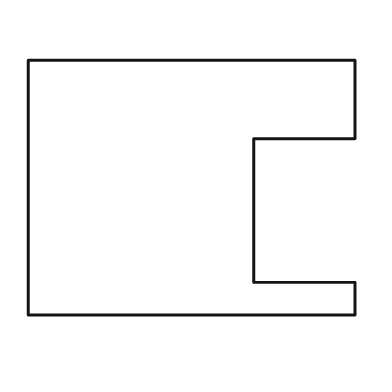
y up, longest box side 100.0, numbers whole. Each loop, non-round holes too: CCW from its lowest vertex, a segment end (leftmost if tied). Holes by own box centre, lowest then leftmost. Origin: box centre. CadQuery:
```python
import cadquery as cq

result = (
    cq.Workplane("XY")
    .moveTo(-50.0, -39.0)
    .lineTo(50.0, -39.0)
    .lineTo(50.0, -29.0)
    .lineTo(19.0, -29.0)
    .lineTo(19.0, 15.0)
    .lineTo(50.0, 15.0)
    .lineTo(50.0, 39.0)
    .lineTo(-50.0, 39.0)
    .close()
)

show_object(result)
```